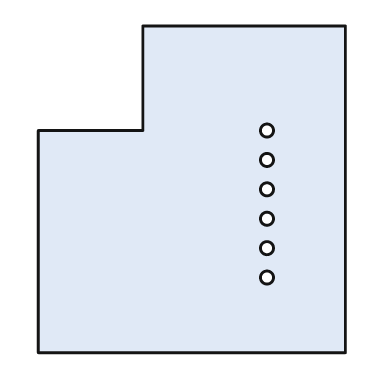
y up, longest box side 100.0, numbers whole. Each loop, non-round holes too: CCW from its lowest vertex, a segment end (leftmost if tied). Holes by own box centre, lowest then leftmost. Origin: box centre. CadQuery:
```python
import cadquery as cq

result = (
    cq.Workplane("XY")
    .moveTo(-47.0, -50.0)
    .lineTo(47.0, -50.0)
    .lineTo(47.0, 50.0)
    .lineTo(-15.0, 50.0)
    .lineTo(-15.0, 18.0)
    .lineTo(-47.0, 18.0)
    .close()
    .moveTo(23.0, -27.0)
    .circle(2.0)
    .moveTo(23.0, -18.0)
    .circle(2.0)
    .moveTo(23.0, -9.0)
    .circle(2.0)
    .moveTo(23.0, 0.0)
    .circle(2.0)
    .moveTo(23.0, 9.0)
    .circle(2.0)
    .moveTo(23.0, 18.0)
    .circle(2.0)
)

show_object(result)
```